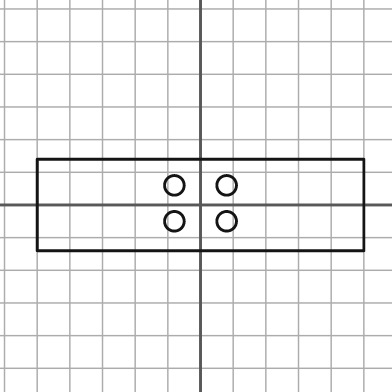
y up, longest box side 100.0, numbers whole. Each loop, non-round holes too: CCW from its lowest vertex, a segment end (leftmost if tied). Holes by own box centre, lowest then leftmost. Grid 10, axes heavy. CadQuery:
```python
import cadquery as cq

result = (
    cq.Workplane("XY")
    .moveTo(-50.0, -14.0)
    .lineTo(50.0, -14.0)
    .lineTo(50.0, 14.0)
    .lineTo(-50.0, 14.0)
    .close()
    .moveTo(-8.0, -5.0)
    .circle(3.0)
    .moveTo(8.0, -5.0)
    .circle(3.0)
    .moveTo(-8.0, 6.0)
    .circle(3.0)
    .moveTo(8.0, 6.0)
    .circle(3.0)
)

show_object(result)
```